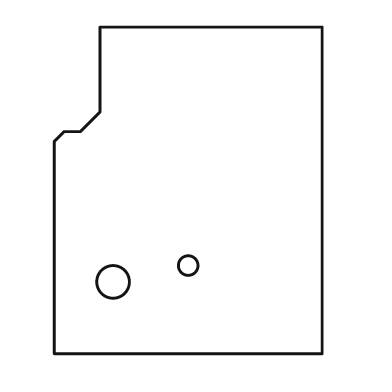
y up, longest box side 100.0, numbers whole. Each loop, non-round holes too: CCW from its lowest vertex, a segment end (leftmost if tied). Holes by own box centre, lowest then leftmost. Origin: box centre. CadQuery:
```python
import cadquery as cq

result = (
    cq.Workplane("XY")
    .moveTo(-41.0, -50.0)
    .lineTo(41.0, -50.0)
    .lineTo(41.0, 50.0)
    .lineTo(-27.0, 50.0)
    .lineTo(-27.0, 24.0)
    .lineTo(-33.0, 18.0)
    .lineTo(-38.0, 18.0)
    .lineTo(-41.0, 15.0)
    .close()
    .moveTo(-23.0, -28.0)
    .circle(5.0)
    .moveTo(0.0, -23.0)
    .circle(3.0)
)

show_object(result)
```